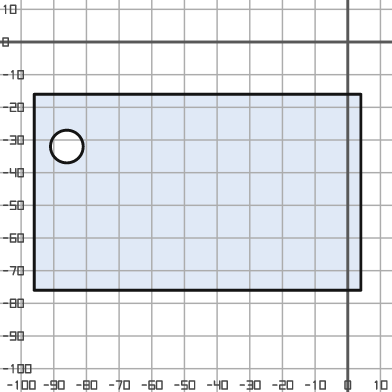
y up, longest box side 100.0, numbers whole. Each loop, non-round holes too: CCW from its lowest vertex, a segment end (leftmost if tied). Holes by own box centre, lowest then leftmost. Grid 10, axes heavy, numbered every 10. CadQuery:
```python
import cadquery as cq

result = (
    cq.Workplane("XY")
    .moveTo(-96.0, -76.0)
    .lineTo(4.0, -76.0)
    .lineTo(4.0, -16.0)
    .lineTo(-96.0, -16.0)
    .close()
    .moveTo(-86.0, -32.0)
    .circle(5.0)
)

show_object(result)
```